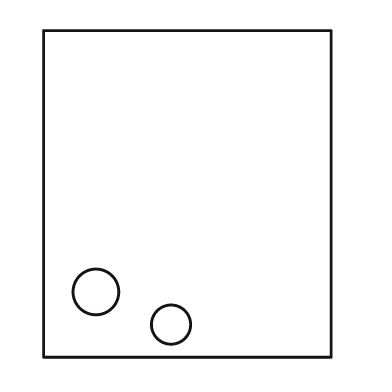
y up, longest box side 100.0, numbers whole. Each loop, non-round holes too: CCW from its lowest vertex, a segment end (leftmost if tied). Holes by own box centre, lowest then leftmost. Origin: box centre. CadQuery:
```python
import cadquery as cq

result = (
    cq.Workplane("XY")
    .moveTo(-44.0, -50.0)
    .lineTo(44.0, -50.0)
    .lineTo(44.0, 50.0)
    .lineTo(-44.0, 50.0)
    .close()
    .moveTo(-5.0, -40.0)
    .circle(6.0)
    .moveTo(-28.0, -30.0)
    .circle(7.0)
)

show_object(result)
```